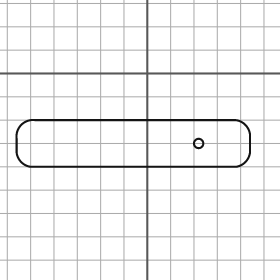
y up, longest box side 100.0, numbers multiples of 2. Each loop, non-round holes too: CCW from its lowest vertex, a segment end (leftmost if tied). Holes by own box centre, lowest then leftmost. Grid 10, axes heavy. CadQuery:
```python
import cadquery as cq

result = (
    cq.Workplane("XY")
    .moveTo(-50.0, -40.0)
    .lineTo(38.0, -40.0)
    .threePointArc((42.0, -38.0), (44.0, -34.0))
    .lineTo(44.0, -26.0)
    .threePointArc((42.0, -22.0), (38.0, -20.0))
    .lineTo(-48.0, -20.0)
    .threePointArc((-54.0, -22.0), (-56.0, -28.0))
    .lineTo(-56.0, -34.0)
    .threePointArc((-54.0, -38.0), (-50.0, -40.0))
    .close()
    .moveTo(22.0, -30.0)
    .circle(2.0)
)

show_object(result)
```